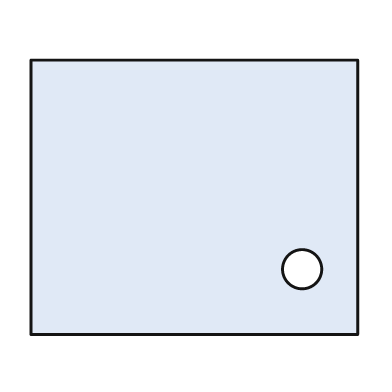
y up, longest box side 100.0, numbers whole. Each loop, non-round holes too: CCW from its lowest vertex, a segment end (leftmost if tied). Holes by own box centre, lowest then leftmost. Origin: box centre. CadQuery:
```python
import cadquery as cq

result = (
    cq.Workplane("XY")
    .moveTo(-50.0, -42.0)
    .lineTo(50.0, -42.0)
    .lineTo(50.0, 42.0)
    .lineTo(-50.0, 42.0)
    .close()
    .moveTo(33.0, -22.0)
    .circle(6.0)
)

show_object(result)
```